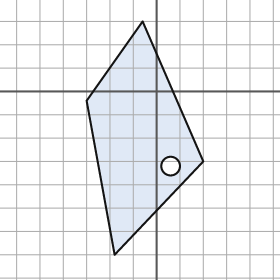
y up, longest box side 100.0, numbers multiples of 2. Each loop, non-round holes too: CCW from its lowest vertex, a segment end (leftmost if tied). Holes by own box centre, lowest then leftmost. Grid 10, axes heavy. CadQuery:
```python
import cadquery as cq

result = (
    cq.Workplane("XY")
    .moveTo(-18.0, -70.0)
    .lineTo(20.0, -30.0)
    .lineTo(-6.0, 30.0)
    .lineTo(-30.0, -4.0)
    .close()
    .moveTo(6.0, -32.0)
    .circle(4.0)
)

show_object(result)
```